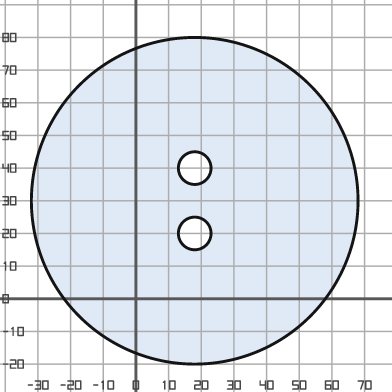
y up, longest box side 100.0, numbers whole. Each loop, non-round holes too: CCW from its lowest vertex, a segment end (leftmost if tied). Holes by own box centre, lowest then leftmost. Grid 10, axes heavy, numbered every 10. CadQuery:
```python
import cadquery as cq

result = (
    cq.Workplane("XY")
    .moveTo(18.0, 30.0)
    .circle(50.0)
    .moveTo(18.0, 20.0)
    .circle(5.0)
    .moveTo(18.0, 40.0)
    .circle(5.0)
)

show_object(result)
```